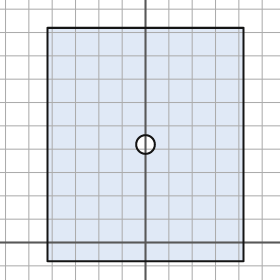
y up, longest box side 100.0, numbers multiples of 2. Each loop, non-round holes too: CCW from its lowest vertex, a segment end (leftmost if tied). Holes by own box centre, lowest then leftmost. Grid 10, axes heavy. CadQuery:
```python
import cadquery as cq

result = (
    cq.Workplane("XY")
    .moveTo(-42.0, -8.0)
    .lineTo(42.0, -8.0)
    .lineTo(42.0, 92.0)
    .lineTo(-42.0, 92.0)
    .close()
    .moveTo(0.0, 42.0)
    .circle(4.0)
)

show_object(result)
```